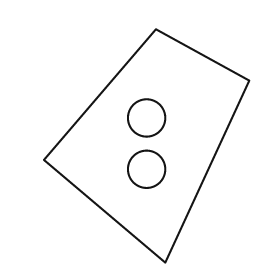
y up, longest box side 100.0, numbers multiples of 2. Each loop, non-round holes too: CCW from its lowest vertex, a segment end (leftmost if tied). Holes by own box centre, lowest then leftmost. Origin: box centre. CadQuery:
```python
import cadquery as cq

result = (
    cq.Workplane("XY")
    .moveTo(8.0, -50.0)
    .lineTo(44.0, 28.0)
    .lineTo(4.0, 50.0)
    .lineTo(-44.0, -6.0)
    .close()
    .moveTo(0.0, -10.0)
    .circle(8.0)
    .moveTo(0.0, 12.0)
    .circle(8.0)
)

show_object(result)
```